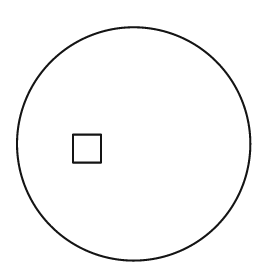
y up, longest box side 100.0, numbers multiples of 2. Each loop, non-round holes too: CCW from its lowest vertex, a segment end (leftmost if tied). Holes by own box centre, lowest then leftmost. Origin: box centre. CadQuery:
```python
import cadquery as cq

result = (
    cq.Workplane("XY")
    .moveTo(0.0, 0.0)
    .circle(50.0)
    .moveTo(-26.0, -8.0)
    .lineTo(-14.0, -8.0)
    .lineTo(-14.0, 4.0)
    .lineTo(-26.0, 4.0)
    .close()
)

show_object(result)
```